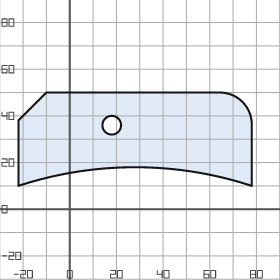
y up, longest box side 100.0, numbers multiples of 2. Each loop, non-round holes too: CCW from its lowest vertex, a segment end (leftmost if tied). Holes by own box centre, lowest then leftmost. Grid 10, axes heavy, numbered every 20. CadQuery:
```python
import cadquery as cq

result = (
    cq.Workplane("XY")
    .moveTo(-22.0, 10.0)
    .threePointArc((28.0, 18.0), (78.0, 10.0))
    .lineTo(78.0, 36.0)
    .threePointArc((74.0, 46.0), (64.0, 50.0))
    .lineTo(-10.0, 50.0)
    .lineTo(-22.0, 38.0)
    .close()
    .moveTo(18.0, 36.0)
    .circle(4.0)
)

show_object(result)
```